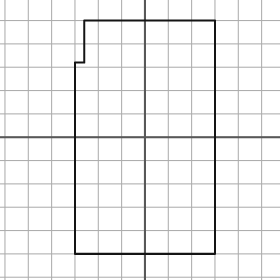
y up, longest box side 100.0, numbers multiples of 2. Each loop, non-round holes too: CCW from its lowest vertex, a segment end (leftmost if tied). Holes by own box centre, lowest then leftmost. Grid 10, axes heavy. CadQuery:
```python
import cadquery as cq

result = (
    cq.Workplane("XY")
    .moveTo(-30.0, -50.0)
    .lineTo(30.0, -50.0)
    .lineTo(30.0, 50.0)
    .lineTo(-26.0, 50.0)
    .lineTo(-26.0, 32.0)
    .lineTo(-30.0, 32.0)
    .close()
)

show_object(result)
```